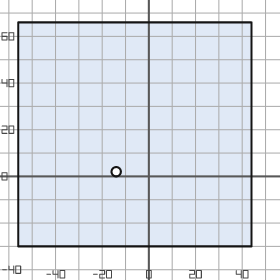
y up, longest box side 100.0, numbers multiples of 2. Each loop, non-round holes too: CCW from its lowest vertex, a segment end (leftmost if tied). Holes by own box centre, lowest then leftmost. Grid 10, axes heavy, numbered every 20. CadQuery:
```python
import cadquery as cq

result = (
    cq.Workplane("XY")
    .moveTo(-56.0, -30.0)
    .lineTo(44.0, -30.0)
    .lineTo(44.0, 66.0)
    .lineTo(-56.0, 66.0)
    .close()
    .moveTo(-14.0, 2.0)
    .circle(2.0)
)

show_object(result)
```